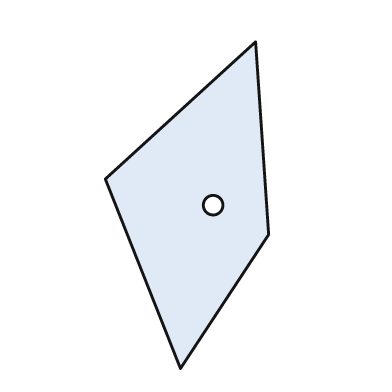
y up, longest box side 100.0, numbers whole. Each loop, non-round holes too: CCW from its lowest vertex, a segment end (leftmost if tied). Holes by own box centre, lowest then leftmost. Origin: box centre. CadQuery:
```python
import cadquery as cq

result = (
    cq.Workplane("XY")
    .moveTo(-2.0, -50.0)
    .lineTo(25.0, -9.0)
    .lineTo(21.0, 50.0)
    .lineTo(-25.0, 8.0)
    .close()
    .moveTo(8.0, 0.0)
    .circle(3.0)
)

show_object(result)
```